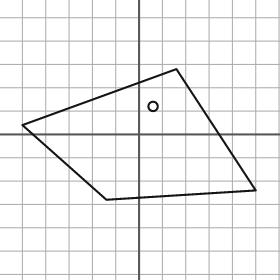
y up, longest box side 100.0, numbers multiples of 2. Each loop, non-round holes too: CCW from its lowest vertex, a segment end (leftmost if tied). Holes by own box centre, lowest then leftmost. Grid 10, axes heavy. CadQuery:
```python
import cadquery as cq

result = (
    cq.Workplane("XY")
    .moveTo(-14.0, -28.0)
    .lineTo(50.0, -24.0)
    .lineTo(16.0, 28.0)
    .lineTo(-50.0, 4.0)
    .close()
    .moveTo(6.0, 12.0)
    .circle(2.0)
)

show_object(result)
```